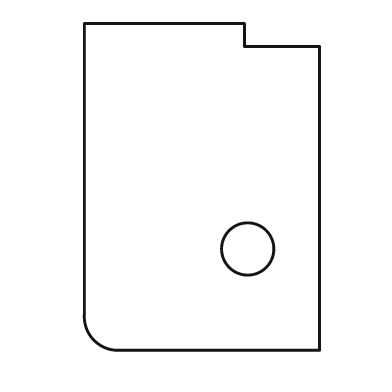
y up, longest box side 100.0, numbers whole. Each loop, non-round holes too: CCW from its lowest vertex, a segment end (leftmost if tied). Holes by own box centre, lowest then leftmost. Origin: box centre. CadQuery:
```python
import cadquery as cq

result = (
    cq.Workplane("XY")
    .moveTo(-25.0, -50.0)
    .lineTo(36.0, -50.0)
    .lineTo(36.0, 43.0)
    .lineTo(13.0, 43.0)
    .lineTo(13.0, 50.0)
    .lineTo(-36.0, 50.0)
    .lineTo(-36.0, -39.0)
    .threePointArc((-33.0, -47.0), (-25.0, -50.0))
    .close()
    .moveTo(14.0, -19.0)
    .circle(8.0)
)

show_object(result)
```